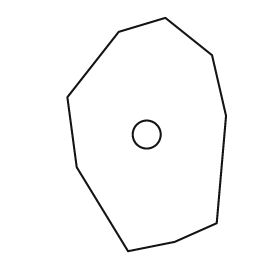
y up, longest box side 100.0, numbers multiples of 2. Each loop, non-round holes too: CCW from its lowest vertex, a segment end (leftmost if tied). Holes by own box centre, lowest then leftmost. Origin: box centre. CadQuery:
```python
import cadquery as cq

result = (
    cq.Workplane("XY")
    .moveTo(-8.0, -50.0)
    .lineTo(12.0, -46.0)
    .lineTo(30.0, -38.0)
    .lineTo(34.0, 8.0)
    .lineTo(28.0, 34.0)
    .lineTo(8.0, 50.0)
    .lineTo(-12.0, 44.0)
    .lineTo(-34.0, 16.0)
    .lineTo(-30.0, -14.0)
    .close()
    .moveTo(0.0, 0.0)
    .circle(6.0)
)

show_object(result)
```